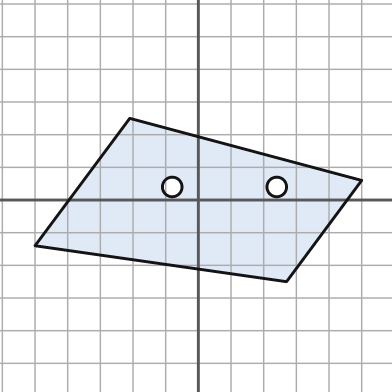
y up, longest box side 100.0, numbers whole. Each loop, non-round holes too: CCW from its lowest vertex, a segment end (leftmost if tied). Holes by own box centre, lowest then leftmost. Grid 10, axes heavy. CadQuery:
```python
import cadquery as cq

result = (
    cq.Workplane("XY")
    .moveTo(27.0, -25.0)
    .lineTo(50.0, 6.0)
    .lineTo(-21.0, 25.0)
    .lineTo(-50.0, -14.0)
    .close()
    .moveTo(-8.0, 4.0)
    .circle(3.0)
    .moveTo(24.0, 4.0)
    .circle(3.0)
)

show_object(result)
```